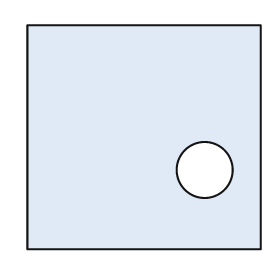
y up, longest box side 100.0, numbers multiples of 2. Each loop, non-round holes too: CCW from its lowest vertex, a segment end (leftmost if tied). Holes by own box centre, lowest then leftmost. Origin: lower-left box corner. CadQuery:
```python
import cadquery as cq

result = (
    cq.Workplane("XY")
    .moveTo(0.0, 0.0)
    .lineTo(100.0, 0.0)
    .lineTo(100.0, 96.0)
    .lineTo(0.0, 96.0)
    .close()
    .moveTo(76.0, 34.0)
    .circle(12.0)
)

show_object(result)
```